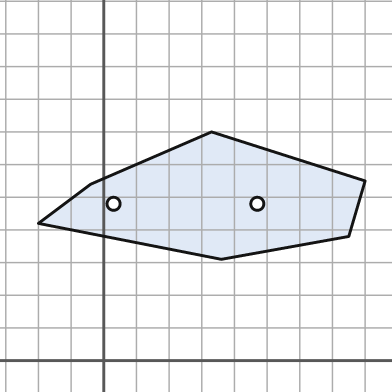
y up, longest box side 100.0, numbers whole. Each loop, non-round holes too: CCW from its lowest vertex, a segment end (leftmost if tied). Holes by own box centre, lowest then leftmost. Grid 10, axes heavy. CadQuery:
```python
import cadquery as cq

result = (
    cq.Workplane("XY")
    .moveTo(36.0, 31.0)
    .lineTo(75.0, 38.0)
    .lineTo(80.0, 55.0)
    .lineTo(33.0, 70.0)
    .lineTo(-4.0, 54.0)
    .lineTo(-20.0, 42.0)
    .close()
    .moveTo(3.0, 48.0)
    .circle(2.0)
    .moveTo(47.0, 48.0)
    .circle(2.0)
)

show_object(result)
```